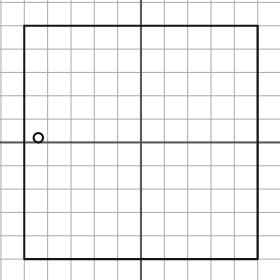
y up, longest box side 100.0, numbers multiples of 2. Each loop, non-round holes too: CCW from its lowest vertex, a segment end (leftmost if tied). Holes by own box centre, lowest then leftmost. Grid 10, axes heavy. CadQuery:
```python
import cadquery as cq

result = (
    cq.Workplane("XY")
    .moveTo(-50.0, -50.0)
    .lineTo(50.0, -50.0)
    .lineTo(50.0, 50.0)
    .lineTo(-50.0, 50.0)
    .close()
    .moveTo(-44.0, 2.0)
    .circle(2.0)
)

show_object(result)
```